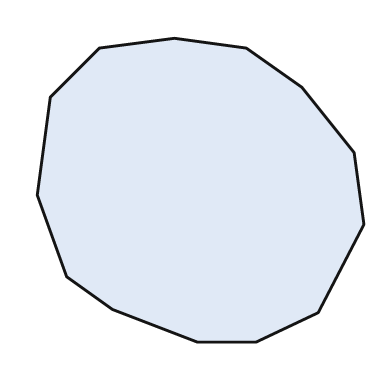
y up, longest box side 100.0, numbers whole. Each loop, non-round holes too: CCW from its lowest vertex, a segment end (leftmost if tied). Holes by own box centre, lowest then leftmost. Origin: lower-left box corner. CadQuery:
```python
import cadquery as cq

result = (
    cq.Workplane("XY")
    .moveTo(49.0, 0.0)
    .lineTo(67.0, 0.0)
    .lineTo(86.0, 9.0)
    .lineTo(100.0, 36.0)
    .lineTo(97.0, 58.0)
    .lineTo(81.0, 78.0)
    .lineTo(64.0, 90.0)
    .lineTo(42.0, 93.0)
    .lineTo(19.0, 90.0)
    .lineTo(4.0, 75.0)
    .lineTo(0.0, 45.0)
    .lineTo(9.0, 20.0)
    .lineTo(23.0, 10.0)
    .close()
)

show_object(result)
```